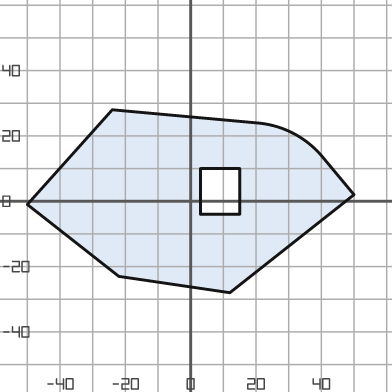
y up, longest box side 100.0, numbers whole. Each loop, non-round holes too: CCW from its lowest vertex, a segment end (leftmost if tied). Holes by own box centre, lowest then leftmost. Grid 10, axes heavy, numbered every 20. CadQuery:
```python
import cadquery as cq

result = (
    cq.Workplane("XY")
    .moveTo(12.0, -28.0)
    .lineTo(50.0, 2.0)
    .lineTo(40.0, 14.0)
    .threePointArc((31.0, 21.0), (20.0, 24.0))
    .lineTo(-24.0, 28.0)
    .lineTo(-50.0, -1.0)
    .lineTo(-22.0, -23.0)
    .close()
    .moveTo(3.0, -4.0)
    .lineTo(15.0, -4.0)
    .lineTo(15.0, 10.0)
    .lineTo(3.0, 10.0)
    .close()
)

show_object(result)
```